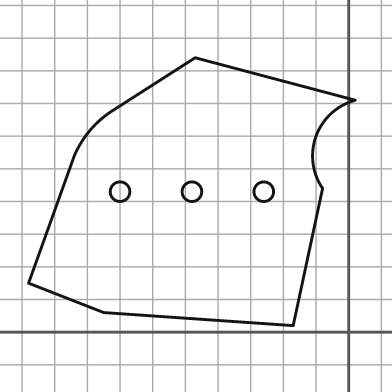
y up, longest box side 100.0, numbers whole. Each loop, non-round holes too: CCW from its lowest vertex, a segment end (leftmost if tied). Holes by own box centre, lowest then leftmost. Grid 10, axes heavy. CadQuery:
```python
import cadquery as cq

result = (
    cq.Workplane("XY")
    .moveTo(-17.0, 2.0)
    .lineTo(-8.0, 44.0)
    .threePointArc((-10.0, 60.0), (2.0, 71.0))
    .lineTo(-47.0, 84.0)
    .lineTo(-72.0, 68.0)
    .threePointArc((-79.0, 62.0), (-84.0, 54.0))
    .lineTo(-98.0, 15.0)
    .lineTo(-75.0, 6.0)
    .close()
    .moveTo(-70.0, 43.0)
    .circle(3.0)
    .moveTo(-48.0, 43.0)
    .circle(3.0)
    .moveTo(-26.0, 43.0)
    .circle(3.0)
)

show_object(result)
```